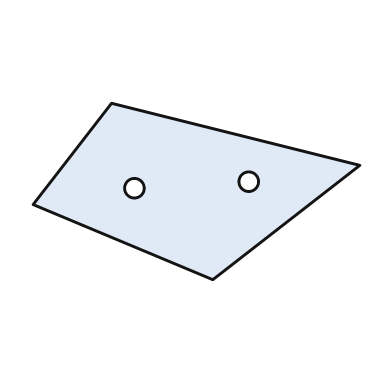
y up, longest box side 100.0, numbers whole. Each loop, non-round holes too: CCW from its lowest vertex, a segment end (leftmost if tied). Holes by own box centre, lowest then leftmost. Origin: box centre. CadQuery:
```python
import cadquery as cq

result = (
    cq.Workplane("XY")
    .moveTo(5.0, -27.0)
    .lineTo(50.0, 8.0)
    .lineTo(-26.0, 27.0)
    .lineTo(-50.0, -4.0)
    .close()
    .moveTo(-19.0, 1.0)
    .circle(3.0)
    .moveTo(16.0, 3.0)
    .circle(3.0)
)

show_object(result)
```